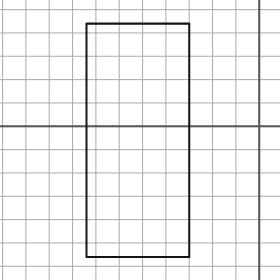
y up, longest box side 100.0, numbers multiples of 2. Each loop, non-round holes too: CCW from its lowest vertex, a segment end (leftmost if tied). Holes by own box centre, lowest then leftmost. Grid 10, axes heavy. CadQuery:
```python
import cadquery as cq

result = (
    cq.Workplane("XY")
    .moveTo(-74.0, -56.0)
    .lineTo(-30.0, -56.0)
    .lineTo(-30.0, 44.0)
    .lineTo(-74.0, 44.0)
    .close()
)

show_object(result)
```